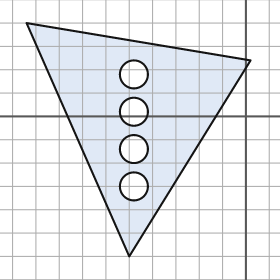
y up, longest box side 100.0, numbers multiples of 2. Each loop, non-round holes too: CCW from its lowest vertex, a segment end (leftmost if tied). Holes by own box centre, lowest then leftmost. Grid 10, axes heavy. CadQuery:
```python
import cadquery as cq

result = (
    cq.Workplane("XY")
    .moveTo(-50.0, -60.0)
    .lineTo(2.0, 24.0)
    .lineTo(-94.0, 40.0)
    .close()
    .moveTo(-48.0, -30.0)
    .circle(6.0)
    .moveTo(-48.0, -14.0)
    .circle(6.0)
    .moveTo(-48.0, 2.0)
    .circle(6.0)
    .moveTo(-48.0, 18.0)
    .circle(6.0)
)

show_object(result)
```